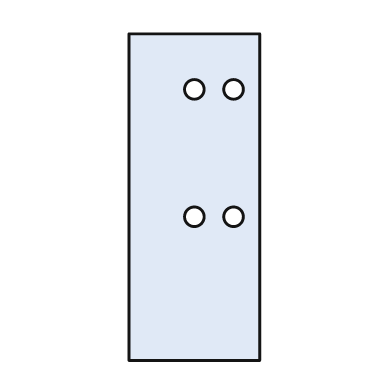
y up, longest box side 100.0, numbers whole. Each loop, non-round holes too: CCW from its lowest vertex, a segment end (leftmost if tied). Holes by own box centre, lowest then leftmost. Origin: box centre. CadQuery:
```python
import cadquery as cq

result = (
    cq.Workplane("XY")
    .moveTo(-20.0, -50.0)
    .lineTo(20.0, -50.0)
    .lineTo(20.0, 50.0)
    .lineTo(-20.0, 50.0)
    .close()
    .moveTo(0.0, -6.0)
    .circle(3.0)
    .moveTo(12.0, -6.0)
    .circle(3.0)
    .moveTo(0.0, 33.0)
    .circle(3.0)
    .moveTo(12.0, 33.0)
    .circle(3.0)
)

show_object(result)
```